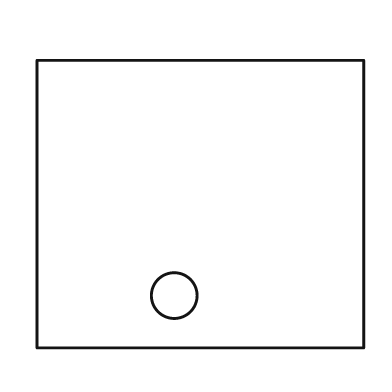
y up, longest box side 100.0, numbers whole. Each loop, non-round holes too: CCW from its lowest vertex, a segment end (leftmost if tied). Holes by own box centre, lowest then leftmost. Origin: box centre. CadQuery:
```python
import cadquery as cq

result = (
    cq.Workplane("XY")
    .moveTo(-50.0, -44.0)
    .lineTo(50.0, -44.0)
    .lineTo(50.0, 44.0)
    .lineTo(-50.0, 44.0)
    .close()
    .moveTo(-8.0, -28.0)
    .circle(7.0)
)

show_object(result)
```